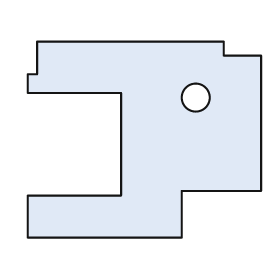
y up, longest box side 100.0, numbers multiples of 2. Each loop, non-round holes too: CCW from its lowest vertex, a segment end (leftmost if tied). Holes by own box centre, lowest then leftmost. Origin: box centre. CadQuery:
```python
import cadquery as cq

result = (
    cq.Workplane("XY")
    .moveTo(-50.0, -42.0)
    .lineTo(16.0, -42.0)
    .lineTo(16.0, -22.0)
    .lineTo(50.0, -22.0)
    .lineTo(50.0, 36.0)
    .lineTo(34.0, 36.0)
    .lineTo(34.0, 42.0)
    .lineTo(-46.0, 42.0)
    .lineTo(-46.0, 28.0)
    .lineTo(-50.0, 28.0)
    .lineTo(-50.0, 20.0)
    .lineTo(-10.0, 20.0)
    .lineTo(-10.0, -24.0)
    .lineTo(-50.0, -24.0)
    .close()
    .moveTo(22.0, 18.0)
    .circle(6.0)
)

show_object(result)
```